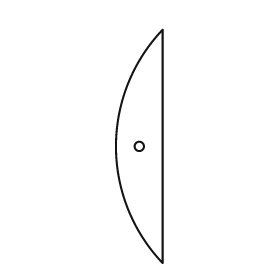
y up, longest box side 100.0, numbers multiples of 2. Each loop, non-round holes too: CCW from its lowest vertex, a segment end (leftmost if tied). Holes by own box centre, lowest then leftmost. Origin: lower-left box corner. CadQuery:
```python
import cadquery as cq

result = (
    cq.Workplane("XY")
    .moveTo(20.0, 0.0)
    .lineTo(20.0, 100.0)
    .threePointArc((0.0, 50.0), (20.0, 0.0))
    .close()
    .moveTo(10.0, 50.0)
    .circle(2.0)
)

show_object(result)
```